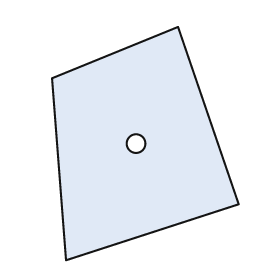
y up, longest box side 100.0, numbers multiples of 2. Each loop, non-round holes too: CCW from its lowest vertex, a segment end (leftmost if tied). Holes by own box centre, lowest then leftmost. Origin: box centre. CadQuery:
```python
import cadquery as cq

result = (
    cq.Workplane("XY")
    .moveTo(-34.0, -50.0)
    .lineTo(40.0, -26.0)
    .lineTo(14.0, 50.0)
    .lineTo(-40.0, 28.0)
    .close()
    .moveTo(-4.0, 0.0)
    .circle(4.0)
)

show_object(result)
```